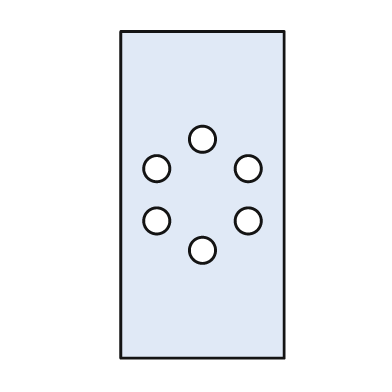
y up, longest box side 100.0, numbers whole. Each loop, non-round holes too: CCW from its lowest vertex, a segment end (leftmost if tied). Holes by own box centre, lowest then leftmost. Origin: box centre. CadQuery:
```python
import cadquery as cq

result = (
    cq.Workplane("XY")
    .moveTo(-25.0, -50.0)
    .lineTo(25.0, -50.0)
    .lineTo(25.0, 50.0)
    .lineTo(-25.0, 50.0)
    .close()
    .moveTo(0.0, -17.0)
    .circle(4.0)
    .moveTo(-14.0, -8.0)
    .circle(4.0)
    .moveTo(14.0, -8.0)
    .circle(4.0)
    .moveTo(-14.0, 8.0)
    .circle(4.0)
    .moveTo(14.0, 8.0)
    .circle(4.0)
    .moveTo(0.0, 17.0)
    .circle(4.0)
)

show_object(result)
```